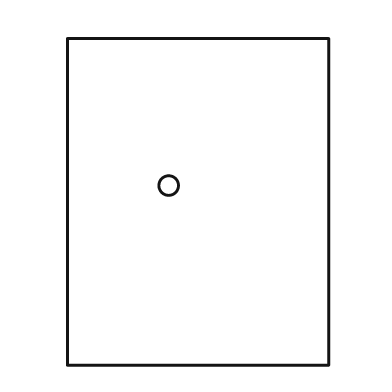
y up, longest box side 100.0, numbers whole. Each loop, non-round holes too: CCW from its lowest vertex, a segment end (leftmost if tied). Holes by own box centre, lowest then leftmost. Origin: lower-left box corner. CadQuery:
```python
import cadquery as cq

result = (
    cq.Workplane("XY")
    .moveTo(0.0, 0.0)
    .lineTo(80.0, 0.0)
    .lineTo(80.0, 100.0)
    .lineTo(0.0, 100.0)
    .close()
    .moveTo(31.0, 55.0)
    .circle(3.0)
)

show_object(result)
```